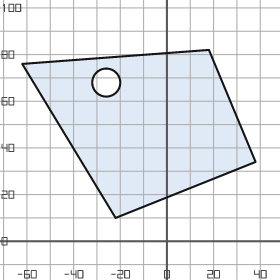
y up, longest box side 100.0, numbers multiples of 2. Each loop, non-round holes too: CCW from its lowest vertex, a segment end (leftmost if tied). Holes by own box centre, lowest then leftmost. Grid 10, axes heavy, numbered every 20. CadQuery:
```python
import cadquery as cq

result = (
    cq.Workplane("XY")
    .moveTo(-22.0, 10.0)
    .lineTo(38.0, 34.0)
    .lineTo(18.0, 82.0)
    .lineTo(-62.0, 76.0)
    .close()
    .moveTo(-26.0, 68.0)
    .circle(6.0)
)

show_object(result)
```